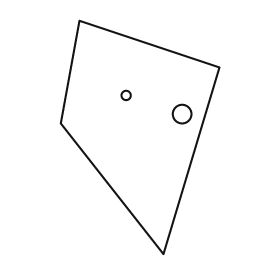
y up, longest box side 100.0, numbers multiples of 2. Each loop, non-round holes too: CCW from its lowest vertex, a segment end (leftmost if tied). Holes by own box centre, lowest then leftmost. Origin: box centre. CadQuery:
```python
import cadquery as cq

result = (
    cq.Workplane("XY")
    .moveTo(10.0, -50.0)
    .lineTo(34.0, 30.0)
    .lineTo(-26.0, 50.0)
    .lineTo(-34.0, 6.0)
    .close()
    .moveTo(18.0, 10.0)
    .circle(4.0)
    .moveTo(-6.0, 18.0)
    .circle(2.0)
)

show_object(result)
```